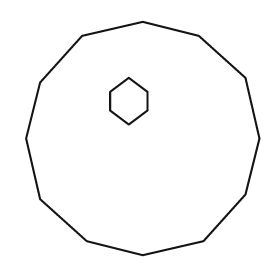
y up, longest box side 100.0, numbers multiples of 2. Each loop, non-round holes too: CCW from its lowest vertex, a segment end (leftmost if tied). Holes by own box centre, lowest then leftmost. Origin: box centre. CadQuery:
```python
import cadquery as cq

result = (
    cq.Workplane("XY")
    .moveTo(0.0, -50.0)
    .lineTo(26.0, -44.0)
    .lineTo(44.0, -24.0)
    .lineTo(50.0, 0.0)
    .lineTo(44.0, 26.0)
    .lineTo(24.0, 44.0)
    .lineTo(0.0, 50.0)
    .lineTo(-26.0, 44.0)
    .lineTo(-44.0, 24.0)
    .lineTo(-50.0, 0.0)
    .lineTo(-44.0, -26.0)
    .lineTo(-24.0, -44.0)
    .close()
    .moveTo(-6.0, 6.0)
    .lineTo(2.0, 12.0)
    .lineTo(2.0, 20.0)
    .lineTo(-6.0, 26.0)
    .lineTo(-14.0, 20.0)
    .lineTo(-14.0, 12.0)
    .close()
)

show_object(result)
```